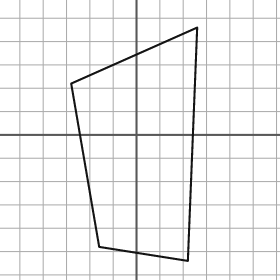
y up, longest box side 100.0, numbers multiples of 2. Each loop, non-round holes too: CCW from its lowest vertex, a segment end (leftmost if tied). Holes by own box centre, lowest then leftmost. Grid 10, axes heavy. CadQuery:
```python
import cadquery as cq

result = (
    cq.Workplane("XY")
    .moveTo(22.0, -54.0)
    .lineTo(26.0, 46.0)
    .lineTo(-28.0, 22.0)
    .lineTo(-16.0, -48.0)
    .close()
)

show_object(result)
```